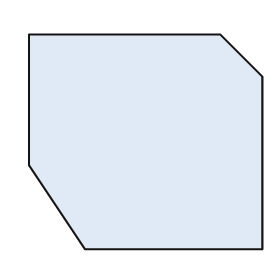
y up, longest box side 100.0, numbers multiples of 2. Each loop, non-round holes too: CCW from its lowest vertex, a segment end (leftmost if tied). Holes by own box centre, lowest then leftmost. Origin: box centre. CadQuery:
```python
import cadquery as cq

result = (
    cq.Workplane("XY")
    .moveTo(-26.0, -46.0)
    .lineTo(50.0, -46.0)
    .lineTo(50.0, 28.0)
    .lineTo(32.0, 46.0)
    .lineTo(-50.0, 46.0)
    .lineTo(-50.0, -10.0)
    .close()
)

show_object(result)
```